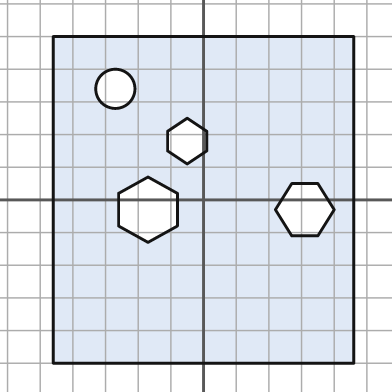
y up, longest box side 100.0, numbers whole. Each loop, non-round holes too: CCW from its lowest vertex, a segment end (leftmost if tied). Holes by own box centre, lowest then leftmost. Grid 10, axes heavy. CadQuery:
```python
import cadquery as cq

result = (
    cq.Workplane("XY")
    .moveTo(-46.0, -50.0)
    .lineTo(46.0, -50.0)
    .lineTo(46.0, 50.0)
    .lineTo(-46.0, 50.0)
    .close()
    .moveTo(-17.0, -13.0)
    .lineTo(-8.0, -8.0)
    .lineTo(-8.0, 2.0)
    .lineTo(-17.0, 7.0)
    .lineTo(-26.0, 2.0)
    .lineTo(-26.0, -8.0)
    .close()
    .moveTo(27.0, -11.0)
    .lineTo(35.0, -11.0)
    .lineTo(40.0, -3.0)
    .lineTo(35.0, 5.0)
    .lineTo(27.0, 5.0)
    .lineTo(22.0, -3.0)
    .close()
    .moveTo(-5.0, 11.0)
    .lineTo(1.0, 15.0)
    .lineTo(1.0, 21.0)
    .lineTo(-5.0, 25.0)
    .lineTo(-11.0, 21.0)
    .lineTo(-11.0, 15.0)
    .close()
    .moveTo(-27.0, 34.0)
    .circle(6.0)
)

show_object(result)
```